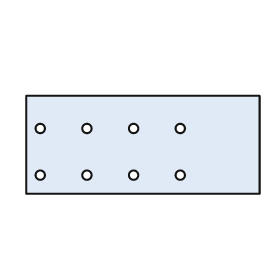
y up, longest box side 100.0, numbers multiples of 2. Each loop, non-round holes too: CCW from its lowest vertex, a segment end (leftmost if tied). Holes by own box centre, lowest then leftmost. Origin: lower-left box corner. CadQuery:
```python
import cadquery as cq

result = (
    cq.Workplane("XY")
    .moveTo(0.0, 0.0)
    .lineTo(100.0, 0.0)
    .lineTo(100.0, 42.0)
    .lineTo(0.0, 42.0)
    .close()
    .moveTo(6.0, 8.0)
    .circle(2.0)
    .moveTo(26.0, 8.0)
    .circle(2.0)
    .moveTo(46.0, 8.0)
    .circle(2.0)
    .moveTo(66.0, 8.0)
    .circle(2.0)
    .moveTo(6.0, 28.0)
    .circle(2.0)
    .moveTo(26.0, 28.0)
    .circle(2.0)
    .moveTo(46.0, 28.0)
    .circle(2.0)
    .moveTo(66.0, 28.0)
    .circle(2.0)
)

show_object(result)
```